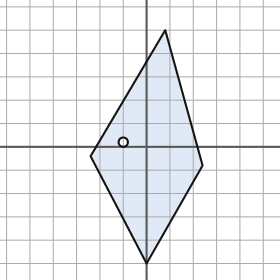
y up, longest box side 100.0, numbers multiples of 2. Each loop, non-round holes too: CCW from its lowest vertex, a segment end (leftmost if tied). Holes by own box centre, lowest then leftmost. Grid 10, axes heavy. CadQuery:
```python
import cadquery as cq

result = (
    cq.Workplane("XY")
    .moveTo(0.0, -50.0)
    .lineTo(24.0, -8.0)
    .lineTo(8.0, 50.0)
    .lineTo(-24.0, -4.0)
    .close()
    .moveTo(-10.0, 2.0)
    .circle(2.0)
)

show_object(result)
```